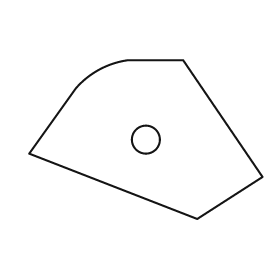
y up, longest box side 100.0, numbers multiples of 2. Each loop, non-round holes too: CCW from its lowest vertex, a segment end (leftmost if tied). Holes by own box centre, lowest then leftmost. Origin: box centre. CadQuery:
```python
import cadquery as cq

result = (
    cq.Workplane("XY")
    .moveTo(22.0, -34.0)
    .lineTo(50.0, -16.0)
    .lineTo(16.0, 34.0)
    .lineTo(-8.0, 34.0)
    .threePointArc((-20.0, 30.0), (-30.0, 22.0))
    .lineTo(-50.0, -6.0)
    .close()
    .moveTo(0.0, 0.0)
    .circle(6.0)
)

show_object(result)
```